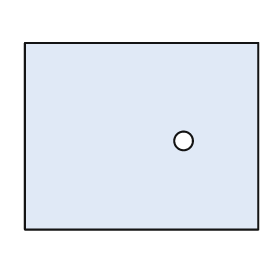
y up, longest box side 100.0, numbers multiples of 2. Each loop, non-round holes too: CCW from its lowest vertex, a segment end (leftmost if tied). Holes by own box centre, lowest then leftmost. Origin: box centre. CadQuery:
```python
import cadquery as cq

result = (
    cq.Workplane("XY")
    .moveTo(-50.0, -40.0)
    .lineTo(50.0, -40.0)
    .lineTo(50.0, 40.0)
    .lineTo(-50.0, 40.0)
    .close()
    .moveTo(18.0, -2.0)
    .circle(4.0)
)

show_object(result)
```